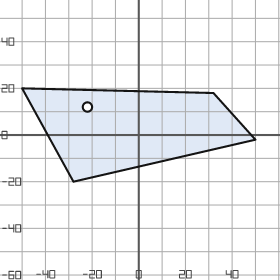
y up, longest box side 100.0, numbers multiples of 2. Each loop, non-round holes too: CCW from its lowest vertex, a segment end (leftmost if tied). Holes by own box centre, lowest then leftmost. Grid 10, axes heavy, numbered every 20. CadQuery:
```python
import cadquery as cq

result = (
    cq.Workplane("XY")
    .moveTo(-28.0, -20.0)
    .lineTo(50.0, -2.0)
    .lineTo(32.0, 18.0)
    .lineTo(-50.0, 20.0)
    .close()
    .moveTo(-22.0, 12.0)
    .circle(2.0)
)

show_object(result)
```